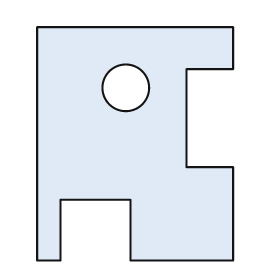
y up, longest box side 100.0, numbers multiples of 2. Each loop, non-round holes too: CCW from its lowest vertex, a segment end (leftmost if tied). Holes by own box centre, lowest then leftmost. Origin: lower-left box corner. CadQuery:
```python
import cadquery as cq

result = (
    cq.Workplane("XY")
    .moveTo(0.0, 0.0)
    .lineTo(10.0, 0.0)
    .lineTo(10.0, 26.0)
    .lineTo(40.0, 26.0)
    .lineTo(40.0, 0.0)
    .lineTo(84.0, 0.0)
    .lineTo(84.0, 40.0)
    .lineTo(64.0, 40.0)
    .lineTo(64.0, 82.0)
    .lineTo(84.0, 82.0)
    .lineTo(84.0, 100.0)
    .lineTo(0.0, 100.0)
    .close()
    .moveTo(38.0, 74.0)
    .circle(10.0)
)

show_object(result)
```